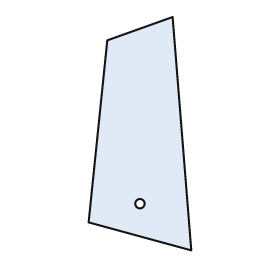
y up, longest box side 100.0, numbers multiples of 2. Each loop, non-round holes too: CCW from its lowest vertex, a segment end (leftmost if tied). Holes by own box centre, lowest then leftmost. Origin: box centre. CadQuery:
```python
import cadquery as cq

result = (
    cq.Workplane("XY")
    .moveTo(22.0, -50.0)
    .lineTo(14.0, 50.0)
    .lineTo(-14.0, 40.0)
    .lineTo(-22.0, -38.0)
    .close()
    .moveTo(0.0, -30.0)
    .circle(2.0)
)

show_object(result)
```